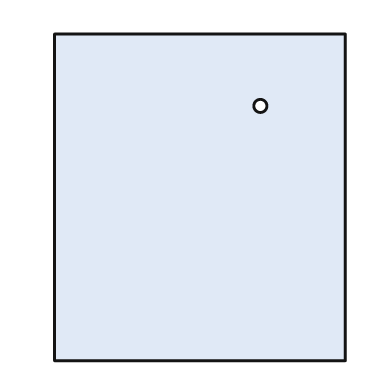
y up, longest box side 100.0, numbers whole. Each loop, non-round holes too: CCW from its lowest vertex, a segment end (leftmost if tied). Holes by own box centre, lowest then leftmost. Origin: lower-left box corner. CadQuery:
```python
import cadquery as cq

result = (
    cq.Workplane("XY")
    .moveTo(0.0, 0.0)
    .lineTo(89.0, 0.0)
    .lineTo(89.0, 100.0)
    .lineTo(0.0, 100.0)
    .close()
    .moveTo(63.0, 78.0)
    .circle(2.0)
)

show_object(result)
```